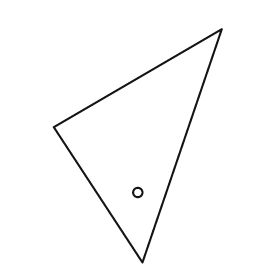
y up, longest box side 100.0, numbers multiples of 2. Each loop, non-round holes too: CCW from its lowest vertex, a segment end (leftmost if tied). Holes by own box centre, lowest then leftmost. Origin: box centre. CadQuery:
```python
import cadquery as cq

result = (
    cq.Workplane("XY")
    .moveTo(2.0, -50.0)
    .lineTo(36.0, 50.0)
    .lineTo(-36.0, 8.0)
    .close()
    .moveTo(0.0, -20.0)
    .circle(2.0)
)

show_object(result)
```